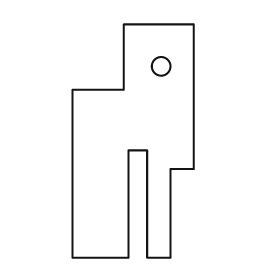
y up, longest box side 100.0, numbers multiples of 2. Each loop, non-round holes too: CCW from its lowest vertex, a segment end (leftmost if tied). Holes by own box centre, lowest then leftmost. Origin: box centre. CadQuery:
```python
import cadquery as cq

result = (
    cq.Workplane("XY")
    .moveTo(-26.0, -50.0)
    .lineTo(-2.0, -50.0)
    .lineTo(-2.0, -4.0)
    .lineTo(6.0, -4.0)
    .lineTo(6.0, -50.0)
    .lineTo(16.0, -50.0)
    .lineTo(16.0, -12.0)
    .lineTo(26.0, -12.0)
    .lineTo(26.0, 50.0)
    .lineTo(-4.0, 50.0)
    .lineTo(-4.0, 22.0)
    .lineTo(-26.0, 22.0)
    .close()
    .moveTo(12.0, 32.0)
    .circle(4.0)
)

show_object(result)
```